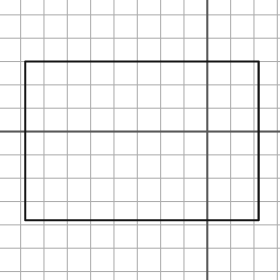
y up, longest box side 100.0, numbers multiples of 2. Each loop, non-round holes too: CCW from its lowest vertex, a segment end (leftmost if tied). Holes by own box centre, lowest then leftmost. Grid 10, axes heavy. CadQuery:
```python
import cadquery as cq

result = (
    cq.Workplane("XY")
    .moveTo(-78.0, -38.0)
    .lineTo(22.0, -38.0)
    .lineTo(22.0, 30.0)
    .lineTo(-78.0, 30.0)
    .close()
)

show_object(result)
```